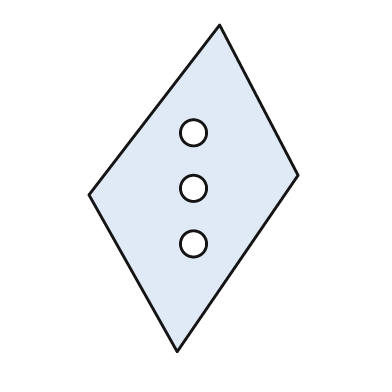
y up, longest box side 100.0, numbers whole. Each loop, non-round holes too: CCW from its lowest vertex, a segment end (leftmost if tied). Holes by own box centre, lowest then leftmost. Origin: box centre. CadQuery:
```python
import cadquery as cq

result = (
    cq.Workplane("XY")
    .moveTo(-5.0, -50.0)
    .lineTo(32.0, 4.0)
    .lineTo(8.0, 50.0)
    .lineTo(-32.0, -2.0)
    .close()
    .moveTo(0.0, -17.0)
    .circle(4.0)
    .moveTo(0.0, 0.0)
    .circle(4.0)
    .moveTo(0.0, 17.0)
    .circle(4.0)
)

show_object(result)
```